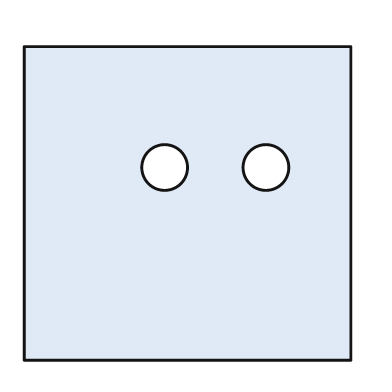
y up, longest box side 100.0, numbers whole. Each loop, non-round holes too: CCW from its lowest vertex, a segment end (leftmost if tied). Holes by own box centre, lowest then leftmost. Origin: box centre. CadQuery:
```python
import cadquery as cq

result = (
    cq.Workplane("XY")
    .moveTo(-50.0, -48.0)
    .lineTo(50.0, -48.0)
    .lineTo(50.0, 48.0)
    .lineTo(-50.0, 48.0)
    .close()
    .moveTo(-7.0, 11.0)
    .circle(7.0)
    .moveTo(24.0, 11.0)
    .circle(7.0)
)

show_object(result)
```